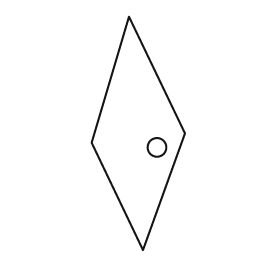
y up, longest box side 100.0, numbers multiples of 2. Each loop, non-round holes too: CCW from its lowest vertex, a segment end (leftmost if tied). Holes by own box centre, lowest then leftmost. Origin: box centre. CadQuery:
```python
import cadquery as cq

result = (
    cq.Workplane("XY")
    .moveTo(2.0, -50.0)
    .lineTo(20.0, 0.0)
    .lineTo(-4.0, 50.0)
    .lineTo(-20.0, -4.0)
    .close()
    .moveTo(8.0, -6.0)
    .circle(4.0)
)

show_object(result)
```